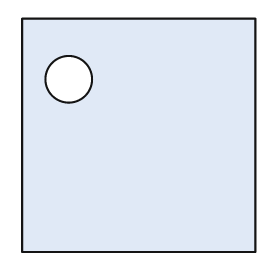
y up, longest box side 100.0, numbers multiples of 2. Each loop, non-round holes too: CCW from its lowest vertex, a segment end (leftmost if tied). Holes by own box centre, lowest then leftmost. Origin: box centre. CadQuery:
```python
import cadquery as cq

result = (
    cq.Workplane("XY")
    .moveTo(-50.0, -50.0)
    .lineTo(50.0, -50.0)
    .lineTo(50.0, 50.0)
    .lineTo(-50.0, 50.0)
    .close()
    .moveTo(-30.0, 24.0)
    .circle(10.0)
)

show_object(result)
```